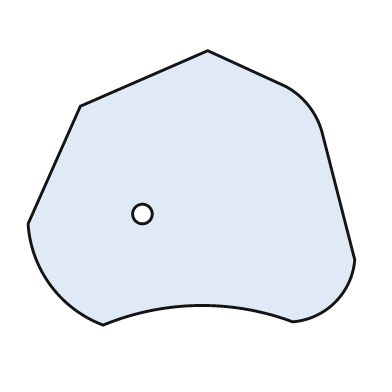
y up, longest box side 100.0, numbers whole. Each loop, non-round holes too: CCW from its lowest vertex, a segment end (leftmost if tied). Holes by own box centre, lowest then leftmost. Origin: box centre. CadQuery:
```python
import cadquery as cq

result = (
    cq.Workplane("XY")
    .moveTo(-27.0, -42.0)
    .threePointArc((2.0, -36.0), (31.0, -41.0))
    .threePointArc((44.0, -35.0), (50.0, -22.0))
    .lineTo(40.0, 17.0)
    .threePointArc((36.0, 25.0), (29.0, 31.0))
    .lineTo(5.0, 42.0)
    .lineTo(-34.0, 25.0)
    .lineTo(-50.0, -11.0)
    .threePointArc((-43.0, -30.0), (-27.0, -42.0))
    .close()
    .moveTo(-15.0, -8.0)
    .circle(3.0)
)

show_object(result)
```